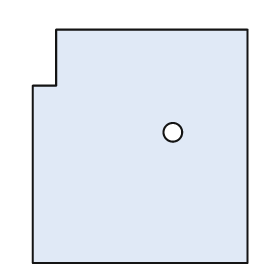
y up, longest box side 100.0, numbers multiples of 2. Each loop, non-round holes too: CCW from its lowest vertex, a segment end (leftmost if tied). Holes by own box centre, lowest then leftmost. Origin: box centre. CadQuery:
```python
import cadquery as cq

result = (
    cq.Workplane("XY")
    .moveTo(-46.0, -50.0)
    .lineTo(46.0, -50.0)
    .lineTo(46.0, 50.0)
    .lineTo(-36.0, 50.0)
    .lineTo(-36.0, 26.0)
    .lineTo(-46.0, 26.0)
    .close()
    .moveTo(14.0, 6.0)
    .circle(4.0)
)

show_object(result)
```